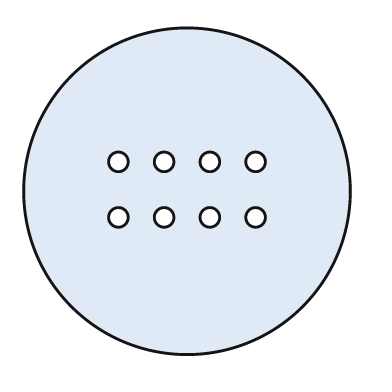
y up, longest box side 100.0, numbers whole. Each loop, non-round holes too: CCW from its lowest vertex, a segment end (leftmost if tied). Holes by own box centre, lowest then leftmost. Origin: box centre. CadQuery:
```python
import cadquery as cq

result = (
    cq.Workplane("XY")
    .moveTo(0.0, 0.0)
    .circle(50.0)
    .moveTo(-21.0, -8.0)
    .circle(3.0)
    .moveTo(-7.0, -8.0)
    .circle(3.0)
    .moveTo(7.0, -8.0)
    .circle(3.0)
    .moveTo(21.0, -8.0)
    .circle(3.0)
    .moveTo(-21.0, 9.0)
    .circle(3.0)
    .moveTo(-7.0, 9.0)
    .circle(3.0)
    .moveTo(7.0, 9.0)
    .circle(3.0)
    .moveTo(21.0, 9.0)
    .circle(3.0)
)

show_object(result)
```